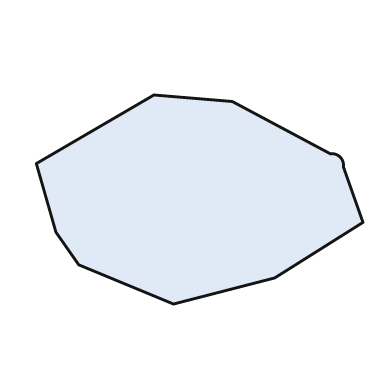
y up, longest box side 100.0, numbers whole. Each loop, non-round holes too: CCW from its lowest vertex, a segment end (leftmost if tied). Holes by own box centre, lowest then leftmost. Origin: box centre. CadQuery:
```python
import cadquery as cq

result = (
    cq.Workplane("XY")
    .moveTo(-8.0, -32.0)
    .lineTo(23.0, -24.0)
    .lineTo(50.0, -7.0)
    .lineTo(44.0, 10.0)
    .threePointArc((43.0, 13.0), (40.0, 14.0))
    .lineTo(10.0, 30.0)
    .lineTo(-14.0, 32.0)
    .lineTo(-50.0, 11.0)
    .lineTo(-44.0, -10.0)
    .lineTo(-37.0, -20.0)
    .close()
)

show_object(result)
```